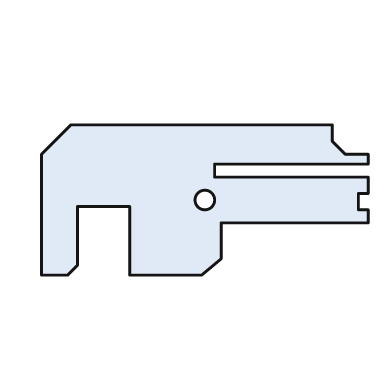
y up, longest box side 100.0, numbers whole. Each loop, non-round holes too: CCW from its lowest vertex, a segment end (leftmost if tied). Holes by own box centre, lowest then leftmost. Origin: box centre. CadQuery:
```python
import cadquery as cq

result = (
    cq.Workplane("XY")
    .moveTo(-50.0, -23.0)
    .lineTo(-42.0, -23.0)
    .lineTo(-39.0, -20.0)
    .lineTo(-39.0, -2.0)
    .lineTo(-23.0, -2.0)
    .lineTo(-23.0, -23.0)
    .lineTo(-1.0, -23.0)
    .lineTo(5.0, -18.0)
    .lineTo(5.0, -7.0)
    .lineTo(50.0, -7.0)
    .lineTo(50.0, -3.0)
    .lineTo(47.0, -3.0)
    .lineTo(47.0, 2.0)
    .lineTo(50.0, 2.0)
    .lineTo(50.0, 7.0)
    .lineTo(3.0, 7.0)
    .lineTo(3.0, 11.0)
    .lineTo(50.0, 11.0)
    .lineTo(50.0, 14.0)
    .lineTo(43.0, 14.0)
    .lineTo(39.0, 18.0)
    .lineTo(39.0, 23.0)
    .lineTo(-41.0, 23.0)
    .lineTo(-50.0, 14.0)
    .close()
    .moveTo(0.0, 0.0)
    .circle(3.0)
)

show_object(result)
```